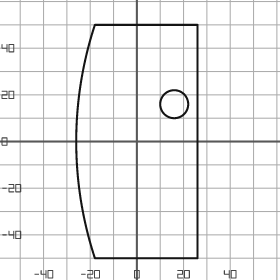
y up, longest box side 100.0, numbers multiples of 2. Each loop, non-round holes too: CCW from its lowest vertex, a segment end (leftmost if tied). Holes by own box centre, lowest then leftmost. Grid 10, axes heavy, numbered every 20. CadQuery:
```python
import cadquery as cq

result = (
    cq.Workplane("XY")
    .moveTo(-18.0, -50.0)
    .lineTo(26.0, -50.0)
    .lineTo(26.0, 50.0)
    .lineTo(-18.0, 50.0)
    .threePointArc((-26.0, 0.0), (-18.0, -50.0))
    .close()
    .moveTo(16.0, 16.0)
    .circle(6.0)
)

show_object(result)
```